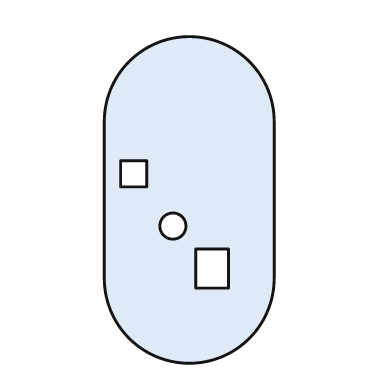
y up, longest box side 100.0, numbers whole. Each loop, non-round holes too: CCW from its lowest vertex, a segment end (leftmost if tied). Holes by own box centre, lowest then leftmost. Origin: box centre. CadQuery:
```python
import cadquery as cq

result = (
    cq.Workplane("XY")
    .moveTo(-26.0, -24.0)
    .threePointArc((0.0, -50.0), (26.0, -24.0))
    .lineTo(26.0, 24.0)
    .threePointArc((0.0, 50.0), (-26.0, 24.0))
    .close()
    .moveTo(2.0, -27.0)
    .lineTo(12.0, -27.0)
    .lineTo(12.0, -15.0)
    .lineTo(2.0, -15.0)
    .close()
    .moveTo(-5.0, -8.0)
    .circle(4.0)
    .moveTo(-21.0, 4.0)
    .lineTo(-13.0, 4.0)
    .lineTo(-13.0, 12.0)
    .lineTo(-21.0, 12.0)
    .close()
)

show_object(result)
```